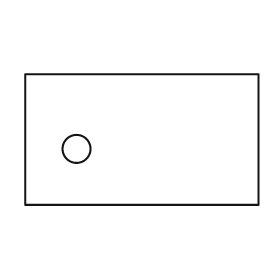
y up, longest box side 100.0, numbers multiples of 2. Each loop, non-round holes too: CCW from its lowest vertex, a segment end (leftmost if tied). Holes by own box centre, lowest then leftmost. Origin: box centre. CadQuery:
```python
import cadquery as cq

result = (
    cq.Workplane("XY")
    .moveTo(-50.0, -28.0)
    .lineTo(50.0, -28.0)
    .lineTo(50.0, 28.0)
    .lineTo(-50.0, 28.0)
    .close()
    .moveTo(-28.0, -4.0)
    .circle(6.0)
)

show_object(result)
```